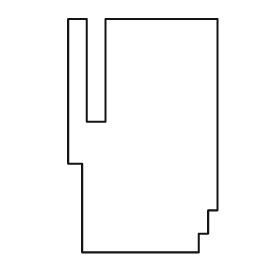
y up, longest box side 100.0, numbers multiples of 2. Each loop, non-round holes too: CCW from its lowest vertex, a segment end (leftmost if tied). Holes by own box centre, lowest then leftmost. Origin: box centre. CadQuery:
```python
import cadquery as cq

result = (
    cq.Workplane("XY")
    .moveTo(-26.0, -50.0)
    .lineTo(24.0, -50.0)
    .lineTo(24.0, -42.0)
    .lineTo(28.0, -42.0)
    .lineTo(28.0, -32.0)
    .lineTo(32.0, -32.0)
    .lineTo(32.0, 50.0)
    .lineTo(-16.0, 50.0)
    .lineTo(-16.0, 6.0)
    .lineTo(-24.0, 6.0)
    .lineTo(-24.0, 50.0)
    .lineTo(-32.0, 50.0)
    .lineTo(-32.0, -12.0)
    .lineTo(-26.0, -12.0)
    .close()
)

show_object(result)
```